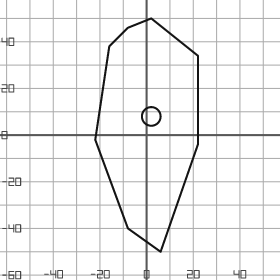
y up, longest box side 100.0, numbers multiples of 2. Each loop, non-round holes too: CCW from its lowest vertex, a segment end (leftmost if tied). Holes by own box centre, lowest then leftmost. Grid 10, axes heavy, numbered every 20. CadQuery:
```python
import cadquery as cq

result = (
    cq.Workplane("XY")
    .moveTo(6.0, -50.0)
    .lineTo(22.0, -4.0)
    .lineTo(22.0, 34.0)
    .lineTo(2.0, 50.0)
    .lineTo(-8.0, 46.0)
    .lineTo(-16.0, 38.0)
    .lineTo(-22.0, -2.0)
    .lineTo(-8.0, -40.0)
    .close()
    .moveTo(2.0, 8.0)
    .circle(4.0)
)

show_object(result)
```